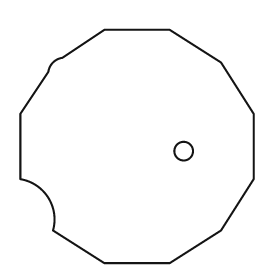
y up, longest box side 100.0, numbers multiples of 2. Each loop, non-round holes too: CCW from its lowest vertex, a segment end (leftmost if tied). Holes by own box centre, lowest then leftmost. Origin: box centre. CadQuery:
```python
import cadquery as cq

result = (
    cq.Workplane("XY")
    .moveTo(-14.0, -50.0)
    .lineTo(14.0, -50.0)
    .lineTo(36.0, -36.0)
    .lineTo(50.0, -14.0)
    .lineTo(50.0, 14.0)
    .lineTo(36.0, 36.0)
    .lineTo(14.0, 50.0)
    .lineTo(-14.0, 50.0)
    .lineTo(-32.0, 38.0)
    .threePointArc((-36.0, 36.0), (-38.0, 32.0))
    .lineTo(-50.0, 14.0)
    .lineTo(-50.0, -14.0)
    .threePointArc((-38.0, -22.0), (-36.0, -36.0))
    .close()
    .moveTo(20.0, -2.0)
    .circle(4.0)
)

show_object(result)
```